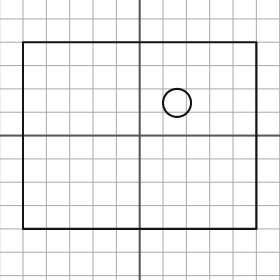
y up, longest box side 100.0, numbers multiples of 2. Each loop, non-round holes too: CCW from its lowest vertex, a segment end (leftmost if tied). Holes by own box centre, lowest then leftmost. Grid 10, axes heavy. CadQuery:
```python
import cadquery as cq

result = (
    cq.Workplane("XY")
    .moveTo(-50.0, -40.0)
    .lineTo(50.0, -40.0)
    .lineTo(50.0, 40.0)
    .lineTo(-50.0, 40.0)
    .close()
    .moveTo(16.0, 14.0)
    .circle(6.0)
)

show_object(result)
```